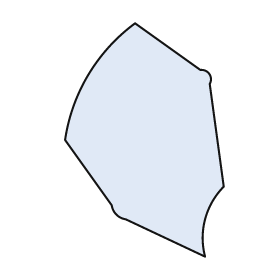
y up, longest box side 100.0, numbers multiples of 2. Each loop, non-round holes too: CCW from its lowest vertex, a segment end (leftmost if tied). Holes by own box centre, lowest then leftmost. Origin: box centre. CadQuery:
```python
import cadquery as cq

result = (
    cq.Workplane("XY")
    .moveTo(26.0, -50.0)
    .threePointArc((26.0, -34.0), (34.0, -20.0))
    .lineTo(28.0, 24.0)
    .threePointArc((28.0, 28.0), (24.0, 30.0))
    .lineTo(-4.0, 50.0)
    .threePointArc((-24.0, 28.0), (-34.0, 0.0))
    .lineTo(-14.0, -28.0)
    .threePointArc((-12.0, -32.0), (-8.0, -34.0))
    .close()
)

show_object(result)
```